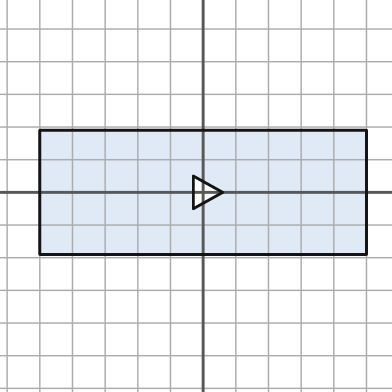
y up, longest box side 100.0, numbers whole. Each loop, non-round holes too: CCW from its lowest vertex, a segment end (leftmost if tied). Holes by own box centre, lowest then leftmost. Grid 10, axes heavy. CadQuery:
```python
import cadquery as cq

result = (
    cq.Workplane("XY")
    .moveTo(-50.0, -19.0)
    .lineTo(50.0, -19.0)
    .lineTo(50.0, 19.0)
    .lineTo(-50.0, 19.0)
    .close()
    .moveTo(-3.0, -5.0)
    .lineTo(6.0, 0.0)
    .lineTo(-3.0, 5.0)
    .close()
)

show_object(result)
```